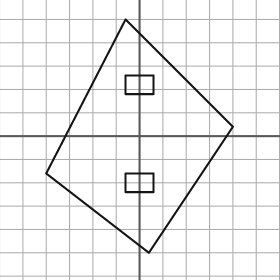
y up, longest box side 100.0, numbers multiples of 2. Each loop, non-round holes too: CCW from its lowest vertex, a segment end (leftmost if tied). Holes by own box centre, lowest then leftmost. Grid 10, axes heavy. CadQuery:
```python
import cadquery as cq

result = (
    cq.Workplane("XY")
    .moveTo(4.0, -50.0)
    .lineTo(40.0, 4.0)
    .lineTo(-6.0, 50.0)
    .lineTo(-40.0, -16.0)
    .close()
    .moveTo(-6.0, -24.0)
    .lineTo(6.0, -24.0)
    .lineTo(6.0, -16.0)
    .lineTo(-6.0, -16.0)
    .close()
    .moveTo(-6.0, 18.0)
    .lineTo(6.0, 18.0)
    .lineTo(6.0, 26.0)
    .lineTo(-6.0, 26.0)
    .close()
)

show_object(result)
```